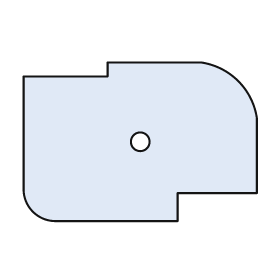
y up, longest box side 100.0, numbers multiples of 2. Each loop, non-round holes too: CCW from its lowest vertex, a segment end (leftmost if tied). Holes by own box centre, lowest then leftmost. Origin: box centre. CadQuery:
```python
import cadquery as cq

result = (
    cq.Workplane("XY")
    .moveTo(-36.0, -34.0)
    .lineTo(16.0, -34.0)
    .lineTo(16.0, -22.0)
    .lineTo(50.0, -22.0)
    .lineTo(50.0, 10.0)
    .threePointArc((42.0, 26.0), (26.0, 34.0))
    .lineTo(-14.0, 34.0)
    .lineTo(-14.0, 28.0)
    .lineTo(-50.0, 28.0)
    .lineTo(-50.0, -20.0)
    .threePointArc((-46.0, -30.0), (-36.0, -34.0))
    .close()
    .moveTo(0.0, 0.0)
    .circle(4.0)
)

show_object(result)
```